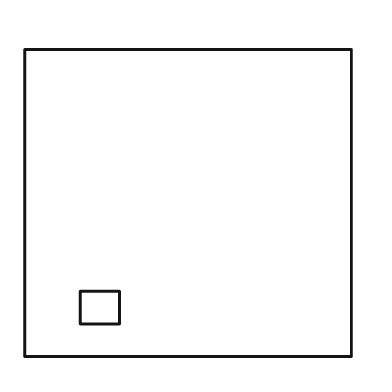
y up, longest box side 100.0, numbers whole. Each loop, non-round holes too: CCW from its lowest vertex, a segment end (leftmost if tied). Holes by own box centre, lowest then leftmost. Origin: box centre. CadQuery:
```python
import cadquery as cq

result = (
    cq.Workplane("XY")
    .moveTo(-50.0, -47.0)
    .lineTo(50.0, -47.0)
    .lineTo(50.0, 47.0)
    .lineTo(-50.0, 47.0)
    .close()
    .moveTo(-33.0, -37.0)
    .lineTo(-21.0, -37.0)
    .lineTo(-21.0, -27.0)
    .lineTo(-33.0, -27.0)
    .close()
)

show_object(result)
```